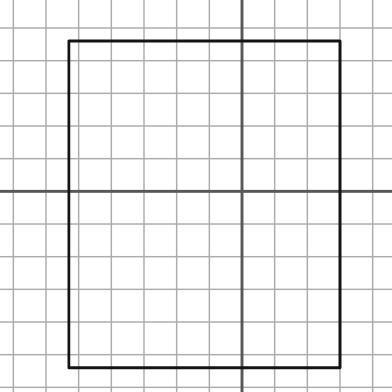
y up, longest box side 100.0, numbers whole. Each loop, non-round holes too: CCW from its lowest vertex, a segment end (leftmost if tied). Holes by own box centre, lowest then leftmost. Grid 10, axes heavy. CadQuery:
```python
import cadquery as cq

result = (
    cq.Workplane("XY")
    .moveTo(-53.0, -54.0)
    .lineTo(30.0, -54.0)
    .lineTo(30.0, 46.0)
    .lineTo(-53.0, 46.0)
    .close()
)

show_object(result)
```